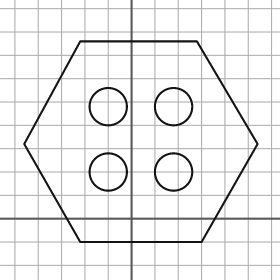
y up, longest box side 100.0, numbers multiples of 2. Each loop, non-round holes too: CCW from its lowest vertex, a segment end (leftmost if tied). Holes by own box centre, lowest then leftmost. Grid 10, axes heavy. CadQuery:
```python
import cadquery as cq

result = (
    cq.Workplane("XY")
    .moveTo(-22.0, -10.0)
    .lineTo(30.0, -10.0)
    .lineTo(54.0, 32.0)
    .lineTo(28.0, 76.0)
    .lineTo(-22.0, 76.0)
    .lineTo(-46.0, 32.0)
    .close()
    .moveTo(-10.0, 20.0)
    .circle(8.0)
    .moveTo(18.0, 20.0)
    .circle(8.0)
    .moveTo(-10.0, 48.0)
    .circle(8.0)
    .moveTo(18.0, 48.0)
    .circle(8.0)
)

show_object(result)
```